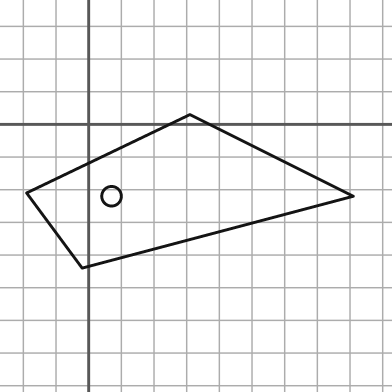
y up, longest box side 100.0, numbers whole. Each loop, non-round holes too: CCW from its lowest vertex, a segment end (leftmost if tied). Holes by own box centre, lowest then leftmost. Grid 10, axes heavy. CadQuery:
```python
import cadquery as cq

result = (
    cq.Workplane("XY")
    .moveTo(-2.0, -44.0)
    .lineTo(81.0, -22.0)
    .lineTo(31.0, 3.0)
    .lineTo(-19.0, -21.0)
    .close()
    .moveTo(7.0, -22.0)
    .circle(3.0)
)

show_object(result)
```